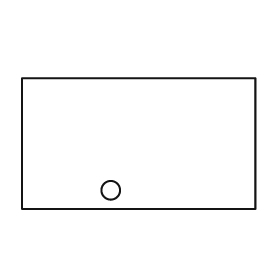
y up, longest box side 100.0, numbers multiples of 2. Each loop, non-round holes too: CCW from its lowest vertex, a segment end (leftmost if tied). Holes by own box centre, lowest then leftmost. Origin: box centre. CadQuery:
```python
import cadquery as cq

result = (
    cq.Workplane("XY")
    .moveTo(-50.0, -28.0)
    .lineTo(50.0, -28.0)
    .lineTo(50.0, 28.0)
    .lineTo(-50.0, 28.0)
    .close()
    .moveTo(-12.0, -20.0)
    .circle(4.0)
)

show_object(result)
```